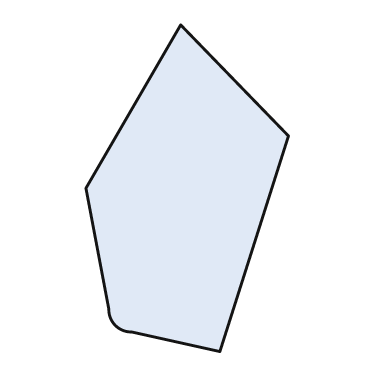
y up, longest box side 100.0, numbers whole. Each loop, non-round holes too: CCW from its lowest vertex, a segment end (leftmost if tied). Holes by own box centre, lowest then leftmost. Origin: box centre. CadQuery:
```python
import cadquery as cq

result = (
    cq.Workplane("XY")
    .moveTo(10.0, -50.0)
    .lineTo(31.0, 16.0)
    .lineTo(-2.0, 50.0)
    .lineTo(-31.0, 0.0)
    .lineTo(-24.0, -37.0)
    .threePointArc((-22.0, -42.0), (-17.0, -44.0))
    .close()
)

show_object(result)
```